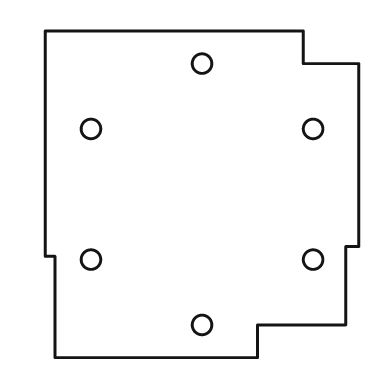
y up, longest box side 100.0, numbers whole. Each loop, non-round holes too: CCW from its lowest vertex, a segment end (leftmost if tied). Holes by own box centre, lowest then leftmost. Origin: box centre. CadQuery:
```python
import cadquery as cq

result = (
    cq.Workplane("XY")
    .moveTo(-45.0, -50.0)
    .lineTo(17.0, -50.0)
    .lineTo(17.0, -40.0)
    .lineTo(44.0, -40.0)
    .lineTo(44.0, -16.0)
    .lineTo(48.0, -16.0)
    .lineTo(48.0, 40.0)
    .lineTo(31.0, 40.0)
    .lineTo(31.0, 50.0)
    .lineTo(-48.0, 50.0)
    .lineTo(-48.0, -19.0)
    .lineTo(-45.0, -19.0)
    .close()
    .moveTo(0.0, -40.0)
    .circle(3.0)
    .moveTo(-34.0, -20.0)
    .circle(3.0)
    .moveTo(34.0, -20.0)
    .circle(3.0)
    .moveTo(-34.0, 20.0)
    .circle(3.0)
    .moveTo(34.0, 20.0)
    .circle(3.0)
    .moveTo(0.0, 40.0)
    .circle(3.0)
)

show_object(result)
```